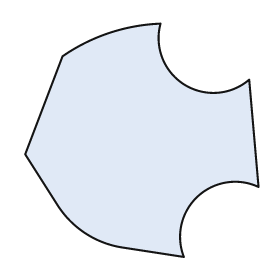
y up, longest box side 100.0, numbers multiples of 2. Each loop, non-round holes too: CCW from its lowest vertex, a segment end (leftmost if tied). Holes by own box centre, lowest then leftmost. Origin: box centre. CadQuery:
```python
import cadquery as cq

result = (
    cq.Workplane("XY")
    .moveTo(18.0, -50.0)
    .threePointArc((24.0, -24.0), (50.0, -20.0))
    .lineTo(46.0, 26.0)
    .threePointArc((18.0, 24.0), (8.0, 50.0))
    .threePointArc((-14.0, 46.0), (-34.0, 36.0))
    .lineTo(-50.0, -6.0)
    .lineTo(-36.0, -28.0)
    .threePointArc((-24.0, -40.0), (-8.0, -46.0))
    .close()
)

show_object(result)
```